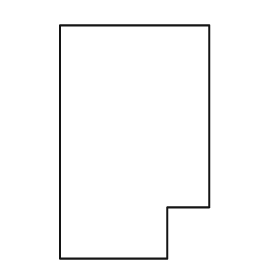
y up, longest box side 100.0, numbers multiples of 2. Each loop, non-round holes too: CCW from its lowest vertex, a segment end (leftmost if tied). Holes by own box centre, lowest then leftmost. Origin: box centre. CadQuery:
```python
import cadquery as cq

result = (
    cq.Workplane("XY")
    .moveTo(-32.0, -50.0)
    .lineTo(14.0, -50.0)
    .lineTo(14.0, -28.0)
    .lineTo(32.0, -28.0)
    .lineTo(32.0, 50.0)
    .lineTo(-32.0, 50.0)
    .close()
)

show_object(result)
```